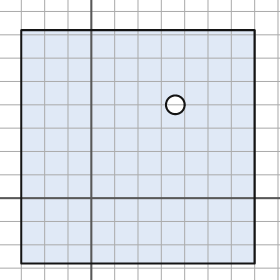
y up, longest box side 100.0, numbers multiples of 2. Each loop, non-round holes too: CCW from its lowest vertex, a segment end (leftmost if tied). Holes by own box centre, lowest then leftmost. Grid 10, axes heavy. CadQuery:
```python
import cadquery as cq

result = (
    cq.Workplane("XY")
    .moveTo(-30.0, -28.0)
    .lineTo(70.0, -28.0)
    .lineTo(70.0, 72.0)
    .lineTo(-30.0, 72.0)
    .close()
    .moveTo(36.0, 40.0)
    .circle(4.0)
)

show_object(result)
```